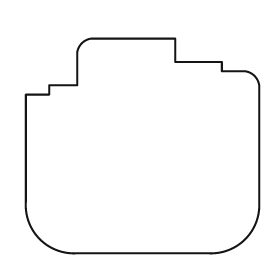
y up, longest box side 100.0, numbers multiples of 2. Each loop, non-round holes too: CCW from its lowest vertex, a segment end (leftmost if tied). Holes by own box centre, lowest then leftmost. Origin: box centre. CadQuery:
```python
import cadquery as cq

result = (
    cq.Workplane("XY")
    .moveTo(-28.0, -46.0)
    .lineTo(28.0, -46.0)
    .threePointArc((44.0, -40.0), (50.0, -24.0))
    .lineTo(50.0, 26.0)
    .threePointArc((48.0, 30.0), (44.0, 32.0))
    .lineTo(34.0, 32.0)
    .lineTo(34.0, 36.0)
    .lineTo(14.0, 36.0)
    .lineTo(14.0, 46.0)
    .lineTo(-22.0, 46.0)
    .threePointArc((-26.0, 44.0), (-28.0, 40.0))
    .lineTo(-28.0, 26.0)
    .lineTo(-40.0, 26.0)
    .lineTo(-40.0, 22.0)
    .lineTo(-50.0, 22.0)
    .lineTo(-50.0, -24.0)
    .threePointArc((-44.0, -40.0), (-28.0, -46.0))
    .close()
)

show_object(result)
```